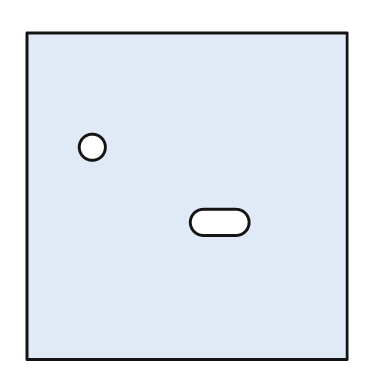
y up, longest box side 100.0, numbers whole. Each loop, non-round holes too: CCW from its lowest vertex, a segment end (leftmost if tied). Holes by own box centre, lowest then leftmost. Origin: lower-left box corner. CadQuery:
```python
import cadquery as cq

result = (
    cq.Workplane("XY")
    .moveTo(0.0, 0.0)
    .lineTo(98.0, 0.0)
    .lineTo(98.0, 100.0)
    .lineTo(0.0, 100.0)
    .close()
    .moveTo(54.0, 38.0)
    .lineTo(64.0, 38.0)
    .threePointArc((68.0, 42.0), (64.0, 46.0))
    .lineTo(54.0, 46.0)
    .threePointArc((50.0, 42.0), (54.0, 38.0))
    .close()
    .moveTo(20.0, 65.0)
    .circle(4.0)
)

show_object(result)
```